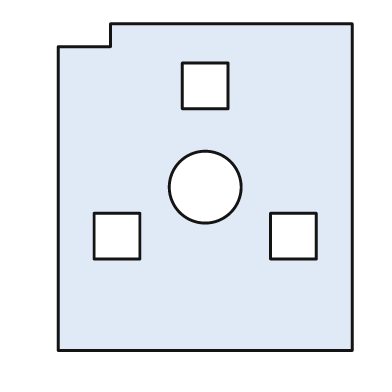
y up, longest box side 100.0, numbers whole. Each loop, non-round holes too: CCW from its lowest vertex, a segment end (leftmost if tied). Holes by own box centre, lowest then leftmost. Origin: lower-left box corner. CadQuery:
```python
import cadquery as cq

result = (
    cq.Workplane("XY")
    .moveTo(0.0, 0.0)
    .lineTo(90.0, 0.0)
    .lineTo(90.0, 100.0)
    .lineTo(16.0, 100.0)
    .lineTo(16.0, 93.0)
    .lineTo(0.0, 93.0)
    .close()
    .moveTo(11.0, 28.0)
    .lineTo(25.0, 28.0)
    .lineTo(25.0, 42.0)
    .lineTo(11.0, 42.0)
    .close()
    .moveTo(65.0, 28.0)
    .lineTo(79.0, 28.0)
    .lineTo(79.0, 42.0)
    .lineTo(65.0, 42.0)
    .close()
    .moveTo(45.0, 50.0)
    .circle(11.0)
    .moveTo(38.0, 74.0)
    .lineTo(52.0, 74.0)
    .lineTo(52.0, 88.0)
    .lineTo(38.0, 88.0)
    .close()
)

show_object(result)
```